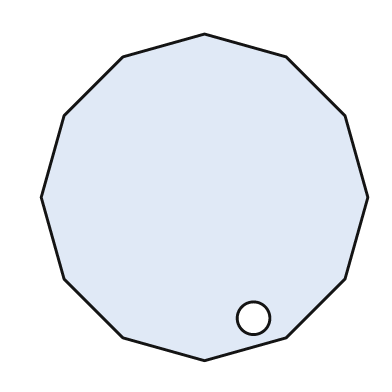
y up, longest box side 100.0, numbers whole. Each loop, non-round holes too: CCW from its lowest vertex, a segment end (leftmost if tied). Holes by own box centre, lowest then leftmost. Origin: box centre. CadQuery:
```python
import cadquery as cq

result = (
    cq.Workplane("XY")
    .moveTo(0.0, -50.0)
    .lineTo(25.0, -43.0)
    .lineTo(43.0, -25.0)
    .lineTo(50.0, 0.0)
    .lineTo(43.0, 25.0)
    .lineTo(25.0, 43.0)
    .lineTo(0.0, 50.0)
    .lineTo(-25.0, 43.0)
    .lineTo(-43.0, 25.0)
    .lineTo(-50.0, 0.0)
    .lineTo(-43.0, -25.0)
    .lineTo(-25.0, -43.0)
    .close()
    .moveTo(15.0, -37.0)
    .circle(5.0)
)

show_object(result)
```